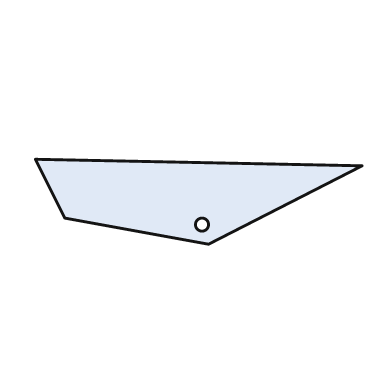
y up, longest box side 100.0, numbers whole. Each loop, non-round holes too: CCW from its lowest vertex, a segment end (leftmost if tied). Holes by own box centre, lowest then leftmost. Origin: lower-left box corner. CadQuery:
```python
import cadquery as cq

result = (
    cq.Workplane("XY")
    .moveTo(53.0, 0.0)
    .lineTo(100.0, 24.0)
    .lineTo(0.0, 26.0)
    .lineTo(9.0, 8.0)
    .close()
    .moveTo(51.0, 6.0)
    .circle(2.0)
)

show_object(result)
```